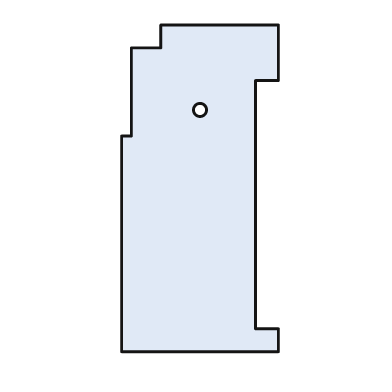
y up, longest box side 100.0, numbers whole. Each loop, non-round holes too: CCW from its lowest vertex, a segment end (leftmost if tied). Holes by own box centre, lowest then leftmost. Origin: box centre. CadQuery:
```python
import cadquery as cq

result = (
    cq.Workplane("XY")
    .moveTo(-24.0, -50.0)
    .lineTo(24.0, -50.0)
    .lineTo(24.0, -43.0)
    .lineTo(17.0, -43.0)
    .lineTo(17.0, 33.0)
    .lineTo(24.0, 33.0)
    .lineTo(24.0, 50.0)
    .lineTo(-12.0, 50.0)
    .lineTo(-12.0, 43.0)
    .lineTo(-21.0, 43.0)
    .lineTo(-21.0, 16.0)
    .lineTo(-24.0, 16.0)
    .close()
    .moveTo(0.0, 24.0)
    .circle(2.0)
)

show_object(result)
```